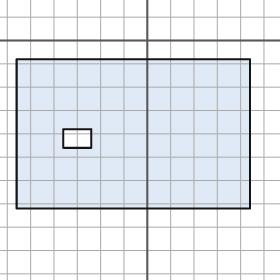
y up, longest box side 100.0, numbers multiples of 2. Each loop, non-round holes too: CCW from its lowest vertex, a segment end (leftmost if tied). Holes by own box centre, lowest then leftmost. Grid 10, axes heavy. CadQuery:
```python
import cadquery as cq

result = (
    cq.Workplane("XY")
    .moveTo(-56.0, -72.0)
    .lineTo(44.0, -72.0)
    .lineTo(44.0, -8.0)
    .lineTo(-56.0, -8.0)
    .close()
    .moveTo(-36.0, -46.0)
    .lineTo(-24.0, -46.0)
    .lineTo(-24.0, -38.0)
    .lineTo(-36.0, -38.0)
    .close()
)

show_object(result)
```